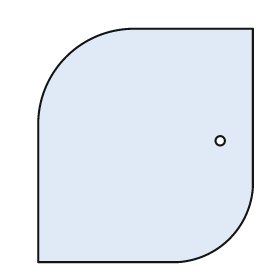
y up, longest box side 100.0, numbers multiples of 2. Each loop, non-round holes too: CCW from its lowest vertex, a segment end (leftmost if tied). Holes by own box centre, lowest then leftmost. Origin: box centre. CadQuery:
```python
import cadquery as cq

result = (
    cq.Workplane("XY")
    .moveTo(-46.0, -50.0)
    .lineTo(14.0, -50.0)
    .threePointArc((36.0, -40.0), (46.0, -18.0))
    .lineTo(46.0, 50.0)
    .lineTo(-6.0, 50.0)
    .threePointArc((-34.0, 38.0), (-46.0, 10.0))
    .close()
    .moveTo(32.0, 2.0)
    .circle(2.0)
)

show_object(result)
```